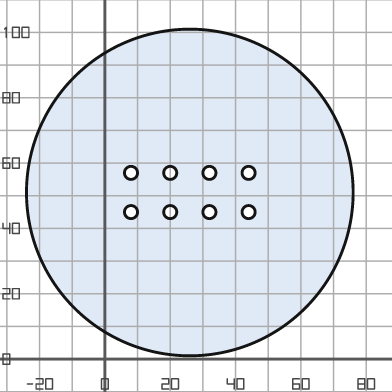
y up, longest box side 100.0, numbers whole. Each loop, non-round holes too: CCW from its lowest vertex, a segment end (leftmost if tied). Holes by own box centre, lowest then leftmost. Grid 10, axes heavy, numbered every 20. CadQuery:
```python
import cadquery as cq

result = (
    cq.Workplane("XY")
    .moveTo(26.0, 51.0)
    .circle(50.0)
    .moveTo(8.0, 45.0)
    .circle(2.0)
    .moveTo(20.0, 45.0)
    .circle(2.0)
    .moveTo(32.0, 45.0)
    .circle(2.0)
    .moveTo(44.0, 45.0)
    .circle(2.0)
    .moveTo(8.0, 57.0)
    .circle(2.0)
    .moveTo(20.0, 57.0)
    .circle(2.0)
    .moveTo(32.0, 57.0)
    .circle(2.0)
    .moveTo(44.0, 57.0)
    .circle(2.0)
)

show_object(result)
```